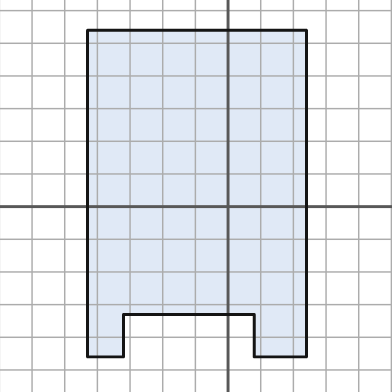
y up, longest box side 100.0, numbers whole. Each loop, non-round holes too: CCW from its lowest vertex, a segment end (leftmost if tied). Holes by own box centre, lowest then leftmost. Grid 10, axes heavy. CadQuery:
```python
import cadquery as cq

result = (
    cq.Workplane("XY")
    .moveTo(-43.0, -46.0)
    .lineTo(-32.0, -46.0)
    .lineTo(-32.0, -33.0)
    .lineTo(8.0, -33.0)
    .lineTo(8.0, -46.0)
    .lineTo(24.0, -46.0)
    .lineTo(24.0, 54.0)
    .lineTo(-43.0, 54.0)
    .close()
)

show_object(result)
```